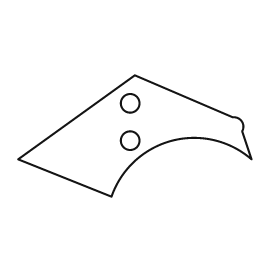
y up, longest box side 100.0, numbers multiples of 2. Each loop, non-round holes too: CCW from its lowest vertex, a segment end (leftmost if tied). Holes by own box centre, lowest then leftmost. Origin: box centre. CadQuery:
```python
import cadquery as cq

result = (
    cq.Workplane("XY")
    .moveTo(-10.0, -26.0)
    .threePointArc((16.0, -2.0), (50.0, -10.0))
    .lineTo(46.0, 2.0)
    .threePointArc((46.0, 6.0), (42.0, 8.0))
    .lineTo(0.0, 26.0)
    .lineTo(-50.0, -10.0)
    .close()
    .moveTo(-2.0, -2.0)
    .circle(4.0)
    .moveTo(-2.0, 14.0)
    .circle(4.0)
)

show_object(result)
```